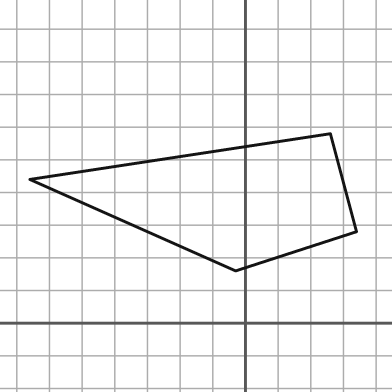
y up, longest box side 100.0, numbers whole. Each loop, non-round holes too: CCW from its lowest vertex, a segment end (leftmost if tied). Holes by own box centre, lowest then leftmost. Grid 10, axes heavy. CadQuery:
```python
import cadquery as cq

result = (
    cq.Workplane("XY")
    .moveTo(-3.0, 16.0)
    .lineTo(34.0, 28.0)
    .lineTo(26.0, 58.0)
    .lineTo(-66.0, 44.0)
    .close()
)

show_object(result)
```